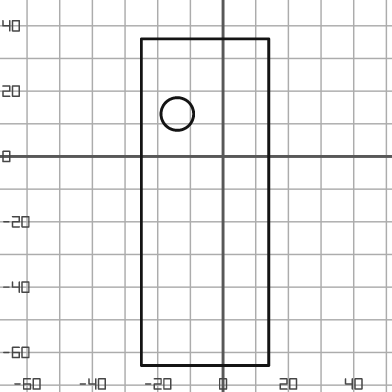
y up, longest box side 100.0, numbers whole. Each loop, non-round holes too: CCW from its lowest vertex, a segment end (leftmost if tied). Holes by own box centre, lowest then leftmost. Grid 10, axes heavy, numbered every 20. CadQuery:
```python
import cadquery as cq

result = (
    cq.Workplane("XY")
    .moveTo(-25.0, -64.0)
    .lineTo(14.0, -64.0)
    .lineTo(14.0, 36.0)
    .lineTo(-25.0, 36.0)
    .close()
    .moveTo(-14.0, 13.0)
    .circle(5.0)
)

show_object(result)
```